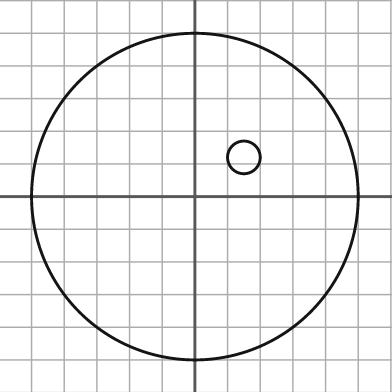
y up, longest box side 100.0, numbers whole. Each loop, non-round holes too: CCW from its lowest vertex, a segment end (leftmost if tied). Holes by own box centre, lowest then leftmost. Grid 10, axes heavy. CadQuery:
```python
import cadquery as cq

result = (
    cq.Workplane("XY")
    .moveTo(0.0, 0.0)
    .circle(50.0)
    .moveTo(15.0, 12.0)
    .circle(5.0)
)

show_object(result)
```